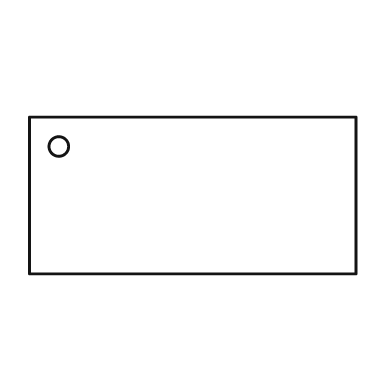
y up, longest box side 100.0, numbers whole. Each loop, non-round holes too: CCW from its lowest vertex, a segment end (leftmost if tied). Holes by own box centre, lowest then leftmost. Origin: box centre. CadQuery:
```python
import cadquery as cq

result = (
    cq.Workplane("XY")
    .moveTo(-50.0, -24.0)
    .lineTo(50.0, -24.0)
    .lineTo(50.0, 24.0)
    .lineTo(-50.0, 24.0)
    .close()
    .moveTo(-41.0, 15.0)
    .circle(3.0)
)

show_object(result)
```